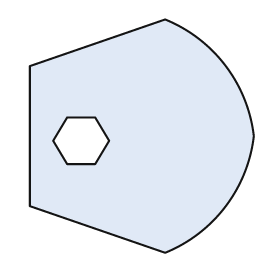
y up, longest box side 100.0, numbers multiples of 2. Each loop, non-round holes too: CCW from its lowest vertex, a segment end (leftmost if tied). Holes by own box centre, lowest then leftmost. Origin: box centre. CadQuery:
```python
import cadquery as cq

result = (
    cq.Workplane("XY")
    .moveTo(10.0, -50.0)
    .threePointArc((36.0, -30.0), (48.0, 0.0))
    .threePointArc((36.0, 30.0), (10.0, 50.0))
    .lineTo(-48.0, 30.0)
    .lineTo(-48.0, -30.0)
    .close()
    .moveTo(-32.0, -12.0)
    .lineTo(-20.0, -12.0)
    .lineTo(-14.0, -2.0)
    .lineTo(-20.0, 8.0)
    .lineTo(-32.0, 8.0)
    .lineTo(-38.0, -2.0)
    .close()
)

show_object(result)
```